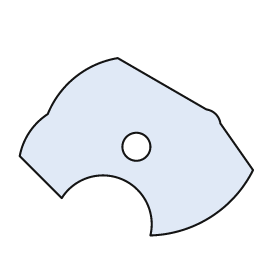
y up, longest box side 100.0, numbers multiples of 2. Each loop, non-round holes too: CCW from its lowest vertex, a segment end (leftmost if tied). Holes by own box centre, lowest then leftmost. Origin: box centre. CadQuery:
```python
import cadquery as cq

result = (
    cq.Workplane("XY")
    .moveTo(6.0, -38.0)
    .threePointArc((32.0, -30.0), (50.0, -10.0))
    .lineTo(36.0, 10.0)
    .threePointArc((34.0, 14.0), (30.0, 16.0))
    .lineTo(-8.0, 38.0)
    .threePointArc((-26.0, 30.0), (-38.0, 14.0))
    .threePointArc((-46.0, 6.0), (-50.0, -4.0))
    .lineTo(-32.0, -22.0)
    .threePointArc((-6.0, -14.0), (6.0, -38.0))
    .close()
    .moveTo(0.0, 0.0)
    .circle(6.0)
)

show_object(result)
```